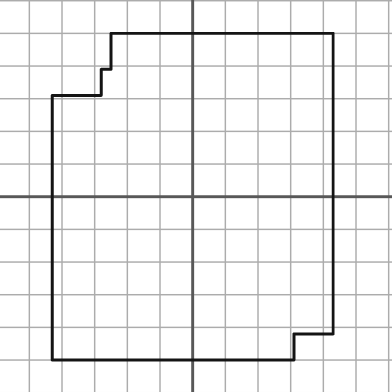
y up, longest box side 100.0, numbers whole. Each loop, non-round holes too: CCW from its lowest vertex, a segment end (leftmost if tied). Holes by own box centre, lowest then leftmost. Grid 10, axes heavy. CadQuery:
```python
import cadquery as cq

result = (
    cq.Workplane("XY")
    .moveTo(-43.0, -50.0)
    .lineTo(31.0, -50.0)
    .lineTo(31.0, -42.0)
    .lineTo(43.0, -42.0)
    .lineTo(43.0, 50.0)
    .lineTo(-25.0, 50.0)
    .lineTo(-25.0, 39.0)
    .lineTo(-28.0, 39.0)
    .lineTo(-28.0, 31.0)
    .lineTo(-43.0, 31.0)
    .close()
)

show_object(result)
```